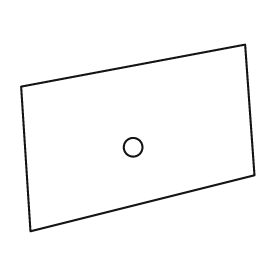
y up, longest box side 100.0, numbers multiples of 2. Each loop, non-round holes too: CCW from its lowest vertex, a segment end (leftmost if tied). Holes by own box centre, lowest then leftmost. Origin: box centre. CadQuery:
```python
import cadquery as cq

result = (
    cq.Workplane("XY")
    .moveTo(-46.0, -40.0)
    .lineTo(50.0, -16.0)
    .lineTo(46.0, 40.0)
    .lineTo(-50.0, 22.0)
    .close()
    .moveTo(-2.0, -4.0)
    .circle(4.0)
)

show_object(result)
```